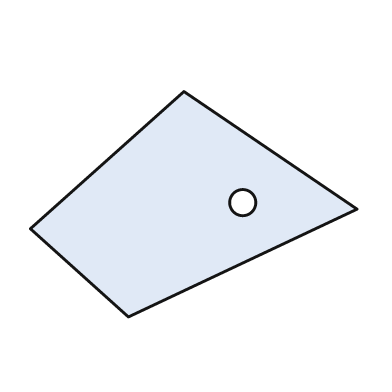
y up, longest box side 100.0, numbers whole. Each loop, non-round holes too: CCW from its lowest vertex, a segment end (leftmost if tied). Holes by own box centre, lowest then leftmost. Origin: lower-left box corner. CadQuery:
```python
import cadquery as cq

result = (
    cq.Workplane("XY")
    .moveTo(30.0, 0.0)
    .lineTo(100.0, 33.0)
    .lineTo(47.0, 69.0)
    .lineTo(0.0, 27.0)
    .close()
    .moveTo(65.0, 35.0)
    .circle(4.0)
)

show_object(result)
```